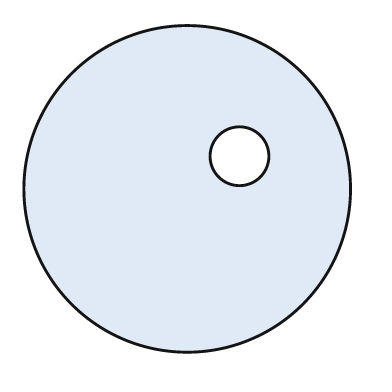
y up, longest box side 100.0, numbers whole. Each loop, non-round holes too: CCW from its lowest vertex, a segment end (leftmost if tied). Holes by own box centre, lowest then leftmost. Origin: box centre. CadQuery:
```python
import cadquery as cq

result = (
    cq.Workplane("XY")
    .moveTo(0.0, 0.0)
    .circle(50.0)
    .moveTo(16.0, 10.0)
    .circle(9.0)
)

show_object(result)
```